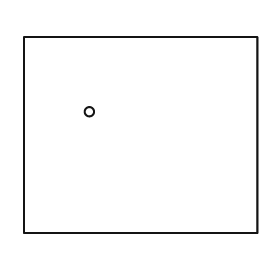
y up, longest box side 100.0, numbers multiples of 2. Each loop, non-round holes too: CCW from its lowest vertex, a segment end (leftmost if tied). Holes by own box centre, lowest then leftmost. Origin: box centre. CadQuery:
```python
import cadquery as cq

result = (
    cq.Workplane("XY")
    .moveTo(-50.0, -42.0)
    .lineTo(50.0, -42.0)
    .lineTo(50.0, 42.0)
    .lineTo(-50.0, 42.0)
    .close()
    .moveTo(-22.0, 10.0)
    .circle(2.0)
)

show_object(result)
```